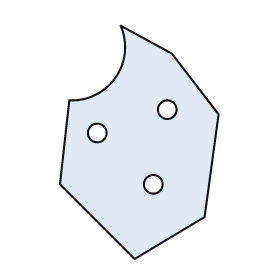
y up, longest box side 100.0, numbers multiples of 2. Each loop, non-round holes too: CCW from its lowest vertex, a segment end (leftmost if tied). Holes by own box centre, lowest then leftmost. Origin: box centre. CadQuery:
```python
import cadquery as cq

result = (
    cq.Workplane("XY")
    .moveTo(-2.0, -50.0)
    .lineTo(28.0, -32.0)
    .lineTo(34.0, 12.0)
    .lineTo(14.0, 38.0)
    .lineTo(-8.0, 50.0)
    .threePointArc((-10.0, 28.0), (-30.0, 18.0))
    .lineTo(-34.0, -18.0)
    .close()
    .moveTo(6.0, -18.0)
    .circle(4.0)
    .moveTo(-18.0, 4.0)
    .circle(4.0)
    .moveTo(12.0, 14.0)
    .circle(4.0)
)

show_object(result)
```